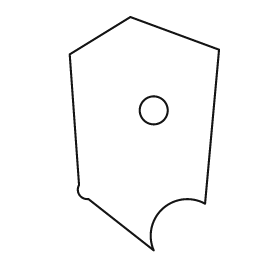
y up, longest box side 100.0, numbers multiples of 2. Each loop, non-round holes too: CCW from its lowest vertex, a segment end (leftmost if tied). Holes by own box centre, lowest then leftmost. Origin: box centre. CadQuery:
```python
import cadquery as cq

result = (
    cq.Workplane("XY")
    .moveTo(4.0, -50.0)
    .threePointArc((8.0, -32.0), (26.0, -30.0))
    .lineTo(32.0, 36.0)
    .lineTo(-6.0, 50.0)
    .lineTo(-32.0, 34.0)
    .lineTo(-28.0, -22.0)
    .threePointArc((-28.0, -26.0), (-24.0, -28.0))
    .close()
    .moveTo(4.0, 10.0)
    .circle(6.0)
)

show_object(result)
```